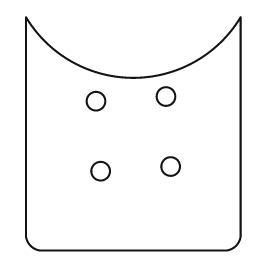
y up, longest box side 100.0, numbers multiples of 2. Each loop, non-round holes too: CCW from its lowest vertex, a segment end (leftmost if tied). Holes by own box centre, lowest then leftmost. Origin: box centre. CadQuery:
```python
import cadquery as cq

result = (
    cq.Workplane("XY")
    .moveTo(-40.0, -50.0)
    .lineTo(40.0, -50.0)
    .threePointArc((44.0, -48.0), (46.0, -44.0))
    .lineTo(46.0, 50.0)
    .threePointArc((0.0, 24.0), (-46.0, 50.0))
    .lineTo(-46.0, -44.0)
    .threePointArc((-44.0, -48.0), (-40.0, -50.0))
    .close()
    .moveTo(-14.0, -16.0)
    .circle(4.0)
    .moveTo(16.0, -14.0)
    .circle(4.0)
    .moveTo(-16.0, 14.0)
    .circle(4.0)
    .moveTo(14.0, 16.0)
    .circle(4.0)
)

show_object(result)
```